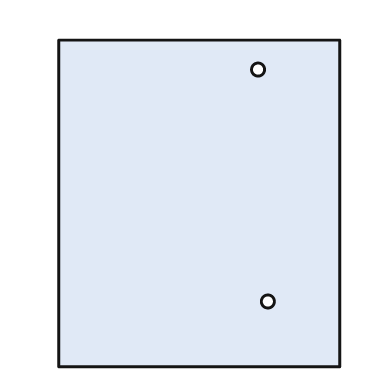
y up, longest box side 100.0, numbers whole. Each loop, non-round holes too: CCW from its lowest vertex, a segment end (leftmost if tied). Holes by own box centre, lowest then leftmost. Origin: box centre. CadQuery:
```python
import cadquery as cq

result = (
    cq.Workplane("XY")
    .moveTo(-43.0, -50.0)
    .lineTo(43.0, -50.0)
    .lineTo(43.0, 50.0)
    .lineTo(-43.0, 50.0)
    .close()
    .moveTo(21.0, -30.0)
    .circle(2.0)
    .moveTo(18.0, 41.0)
    .circle(2.0)
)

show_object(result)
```